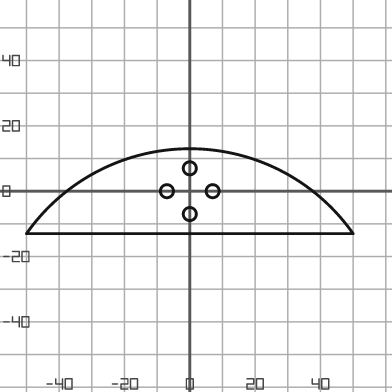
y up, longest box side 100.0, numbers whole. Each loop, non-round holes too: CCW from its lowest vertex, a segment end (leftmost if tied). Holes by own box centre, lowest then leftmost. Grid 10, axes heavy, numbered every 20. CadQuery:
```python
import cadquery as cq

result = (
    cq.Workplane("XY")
    .moveTo(-50.0, -13.0)
    .lineTo(50.0, -13.0)
    .threePointArc((0.0, 13.0), (-50.0, -13.0))
    .close()
    .moveTo(0.0, -7.0)
    .circle(2.0)
    .moveTo(-7.0, 0.0)
    .circle(2.0)
    .moveTo(7.0, 0.0)
    .circle(2.0)
    .moveTo(0.0, 7.0)
    .circle(2.0)
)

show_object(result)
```